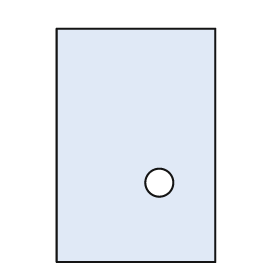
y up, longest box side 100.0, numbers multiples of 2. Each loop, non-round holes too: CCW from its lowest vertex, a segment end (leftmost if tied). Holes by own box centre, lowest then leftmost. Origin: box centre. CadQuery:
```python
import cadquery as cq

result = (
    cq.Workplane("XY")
    .moveTo(-34.0, -50.0)
    .lineTo(34.0, -50.0)
    .lineTo(34.0, 50.0)
    .lineTo(-34.0, 50.0)
    .close()
    .moveTo(10.0, -16.0)
    .circle(6.0)
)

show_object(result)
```